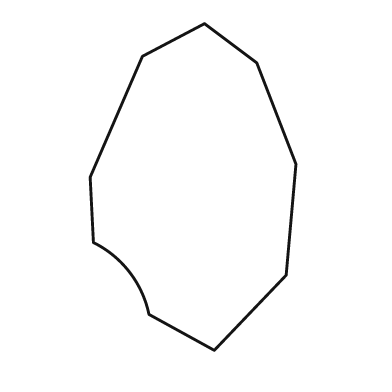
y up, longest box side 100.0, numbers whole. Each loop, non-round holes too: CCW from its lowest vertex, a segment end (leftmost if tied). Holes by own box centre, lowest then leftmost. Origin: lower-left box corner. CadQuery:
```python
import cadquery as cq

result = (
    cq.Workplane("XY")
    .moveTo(38.0, 0.0)
    .lineTo(60.0, 23.0)
    .lineTo(63.0, 57.0)
    .lineTo(51.0, 88.0)
    .lineTo(35.0, 100.0)
    .lineTo(16.0, 90.0)
    .lineTo(0.0, 53.0)
    .lineTo(1.0, 33.0)
    .threePointArc((12.0, 24.0), (18.0, 11.0))
    .close()
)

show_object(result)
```